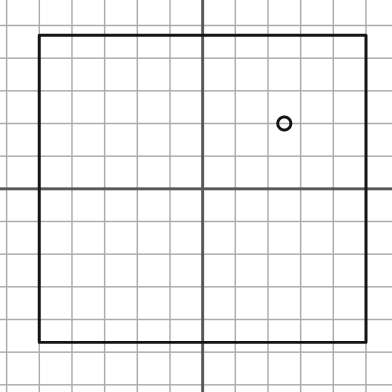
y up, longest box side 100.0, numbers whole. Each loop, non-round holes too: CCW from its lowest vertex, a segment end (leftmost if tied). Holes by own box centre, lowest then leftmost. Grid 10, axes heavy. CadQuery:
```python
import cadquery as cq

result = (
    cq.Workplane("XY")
    .moveTo(-50.0, -47.0)
    .lineTo(50.0, -47.0)
    .lineTo(50.0, 47.0)
    .lineTo(-50.0, 47.0)
    .close()
    .moveTo(25.0, 20.0)
    .circle(2.0)
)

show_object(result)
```